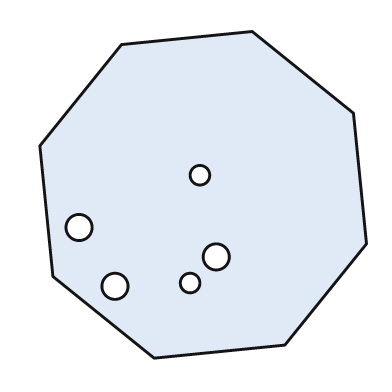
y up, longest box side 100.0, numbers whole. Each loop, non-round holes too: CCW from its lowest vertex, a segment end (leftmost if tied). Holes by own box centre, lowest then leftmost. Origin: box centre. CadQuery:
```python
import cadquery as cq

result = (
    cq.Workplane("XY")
    .moveTo(-15.0, -50.0)
    .lineTo(25.0, -46.0)
    .lineTo(50.0, -15.0)
    .lineTo(46.0, 25.0)
    .lineTo(15.0, 50.0)
    .lineTo(-25.0, 46.0)
    .lineTo(-50.0, 15.0)
    .lineTo(-46.0, -25.0)
    .close()
    .moveTo(-27.0, -28.0)
    .circle(4.0)
    .moveTo(-4.0, -27.0)
    .circle(3.0)
    .moveTo(4.0, -19.0)
    .circle(4.0)
    .moveTo(-38.0, -10.0)
    .circle(4.0)
    .moveTo(-1.0, 6.0)
    .circle(3.0)
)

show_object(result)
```